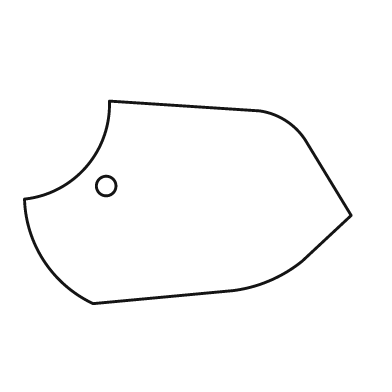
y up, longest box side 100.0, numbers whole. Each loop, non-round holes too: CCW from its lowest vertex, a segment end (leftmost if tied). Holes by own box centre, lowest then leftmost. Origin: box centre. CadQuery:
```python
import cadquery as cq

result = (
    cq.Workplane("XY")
    .moveTo(-29.0, -31.0)
    .lineTo(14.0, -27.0)
    .threePointArc((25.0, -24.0), (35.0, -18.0))
    .lineTo(50.0, -4.0)
    .lineTo(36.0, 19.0)
    .threePointArc((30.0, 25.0), (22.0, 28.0))
    .lineTo(-24.0, 31.0)
    .threePointArc((-31.0, 11.0), (-50.0, 1.0))
    .threePointArc((-44.0, -18.0), (-29.0, -31.0))
    .close()
    .moveTo(-25.0, 5.0)
    .circle(3.0)
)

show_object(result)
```